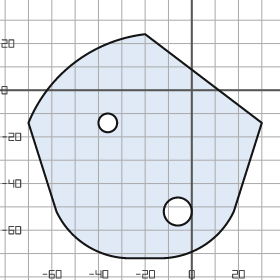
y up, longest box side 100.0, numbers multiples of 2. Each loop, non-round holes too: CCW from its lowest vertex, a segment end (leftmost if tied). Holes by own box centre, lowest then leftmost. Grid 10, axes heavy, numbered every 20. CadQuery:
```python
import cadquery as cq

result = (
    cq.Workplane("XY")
    .moveTo(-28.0, -72.0)
    .lineTo(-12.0, -72.0)
    .threePointArc((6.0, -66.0), (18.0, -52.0))
    .lineTo(30.0, -14.0)
    .lineTo(-20.0, 24.0)
    .threePointArc((-50.0, 12.0), (-70.0, -14.0))
    .lineTo(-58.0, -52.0)
    .threePointArc((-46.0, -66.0), (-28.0, -72.0))
    .close()
    .moveTo(-6.0, -52.0)
    .circle(6.0)
    .moveTo(-36.0, -14.0)
    .circle(4.0)
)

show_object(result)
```